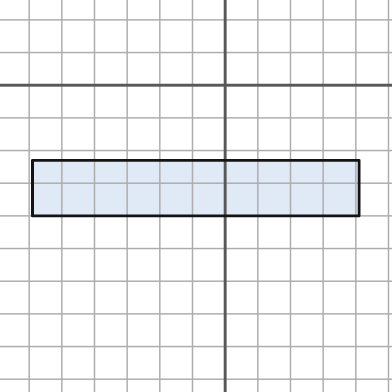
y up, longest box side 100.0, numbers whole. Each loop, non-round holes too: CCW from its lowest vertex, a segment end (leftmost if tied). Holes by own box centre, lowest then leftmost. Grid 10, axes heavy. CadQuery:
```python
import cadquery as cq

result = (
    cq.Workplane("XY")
    .moveTo(-59.0, -40.0)
    .lineTo(41.0, -40.0)
    .lineTo(41.0, -23.0)
    .lineTo(-59.0, -23.0)
    .close()
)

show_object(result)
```